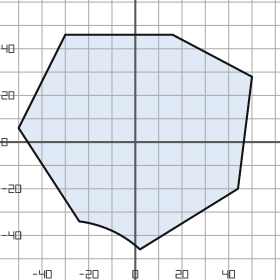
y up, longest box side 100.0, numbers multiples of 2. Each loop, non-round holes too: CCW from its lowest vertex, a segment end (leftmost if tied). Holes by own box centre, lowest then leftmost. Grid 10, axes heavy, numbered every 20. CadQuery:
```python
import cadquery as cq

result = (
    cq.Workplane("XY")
    .moveTo(2.0, -46.0)
    .lineTo(44.0, -20.0)
    .lineTo(50.0, 28.0)
    .lineTo(16.0, 46.0)
    .lineTo(-30.0, 46.0)
    .lineTo(-50.0, 6.0)
    .lineTo(-24.0, -34.0)
    .threePointArc((-10.0, -38.0), (2.0, -46.0))
    .close()
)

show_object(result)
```